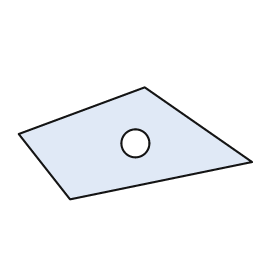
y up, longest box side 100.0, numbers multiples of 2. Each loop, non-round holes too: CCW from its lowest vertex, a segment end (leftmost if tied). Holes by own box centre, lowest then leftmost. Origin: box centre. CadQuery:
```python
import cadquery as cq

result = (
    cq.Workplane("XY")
    .moveTo(-28.0, -24.0)
    .lineTo(50.0, -8.0)
    .lineTo(4.0, 24.0)
    .lineTo(-50.0, 4.0)
    .close()
    .moveTo(0.0, 0.0)
    .circle(6.0)
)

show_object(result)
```